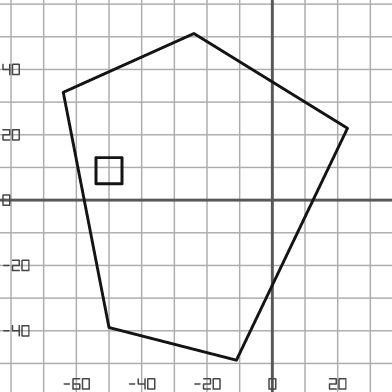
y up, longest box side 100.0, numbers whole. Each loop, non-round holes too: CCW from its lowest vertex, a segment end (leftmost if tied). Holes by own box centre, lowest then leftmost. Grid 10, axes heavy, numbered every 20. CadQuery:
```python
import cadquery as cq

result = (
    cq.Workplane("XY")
    .moveTo(-11.0, -49.0)
    .lineTo(23.0, 22.0)
    .lineTo(-24.0, 51.0)
    .lineTo(-64.0, 33.0)
    .lineTo(-50.0, -39.0)
    .close()
    .moveTo(-54.0, 5.0)
    .lineTo(-46.0, 5.0)
    .lineTo(-46.0, 13.0)
    .lineTo(-54.0, 13.0)
    .close()
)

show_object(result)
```